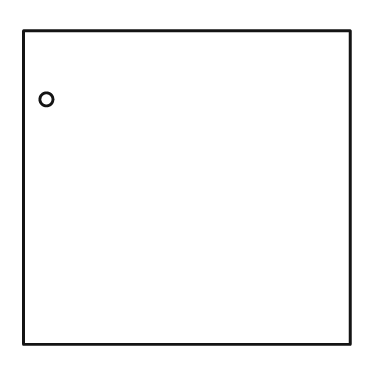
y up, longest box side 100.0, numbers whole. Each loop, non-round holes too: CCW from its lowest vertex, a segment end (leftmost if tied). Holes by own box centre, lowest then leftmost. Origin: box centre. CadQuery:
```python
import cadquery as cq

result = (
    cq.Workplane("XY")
    .moveTo(-50.0, -48.0)
    .lineTo(50.0, -48.0)
    .lineTo(50.0, 48.0)
    .lineTo(-50.0, 48.0)
    .close()
    .moveTo(-43.0, 27.0)
    .circle(2.0)
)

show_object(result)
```